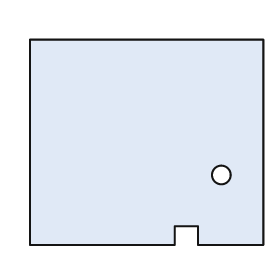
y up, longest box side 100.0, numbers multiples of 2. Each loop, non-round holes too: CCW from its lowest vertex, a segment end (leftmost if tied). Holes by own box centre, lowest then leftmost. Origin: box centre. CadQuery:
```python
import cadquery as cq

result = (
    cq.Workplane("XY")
    .moveTo(-50.0, -44.0)
    .lineTo(12.0, -44.0)
    .lineTo(12.0, -36.0)
    .lineTo(22.0, -36.0)
    .lineTo(22.0, -44.0)
    .lineTo(50.0, -44.0)
    .lineTo(50.0, 44.0)
    .lineTo(-50.0, 44.0)
    .close()
    .moveTo(32.0, -14.0)
    .circle(4.0)
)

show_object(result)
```